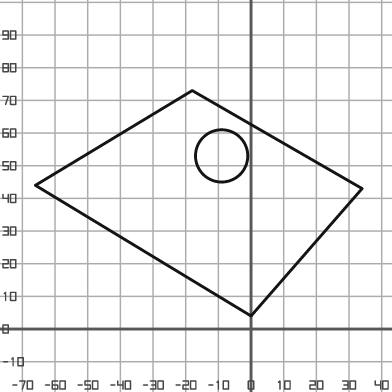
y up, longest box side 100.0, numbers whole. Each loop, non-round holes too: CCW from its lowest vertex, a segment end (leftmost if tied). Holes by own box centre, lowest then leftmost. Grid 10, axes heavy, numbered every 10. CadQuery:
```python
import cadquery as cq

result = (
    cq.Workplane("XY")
    .moveTo(0.0, 4.0)
    .lineTo(34.0, 43.0)
    .lineTo(-18.0, 73.0)
    .lineTo(-66.0, 44.0)
    .close()
    .moveTo(-9.0, 53.0)
    .circle(8.0)
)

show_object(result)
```